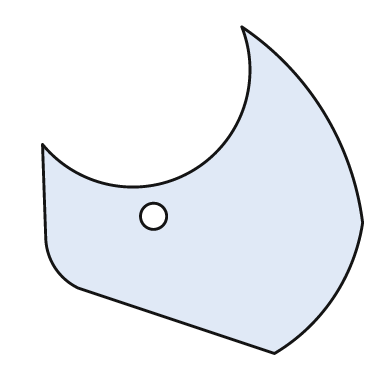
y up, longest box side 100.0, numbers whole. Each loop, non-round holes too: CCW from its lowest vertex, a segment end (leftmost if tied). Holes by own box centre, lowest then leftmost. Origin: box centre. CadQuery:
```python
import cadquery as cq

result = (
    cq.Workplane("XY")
    .moveTo(22.0, -50.0)
    .threePointArc((40.0, -33.0), (49.0, -10.0))
    .threePointArc((37.0, 24.0), (12.0, 50.0))
    .threePointArc((-3.0, 6.0), (-49.0, 14.0))
    .lineTo(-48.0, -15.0)
    .threePointArc((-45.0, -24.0), (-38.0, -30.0))
    .close()
    .moveTo(-15.0, -8.0)
    .circle(4.0)
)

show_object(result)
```